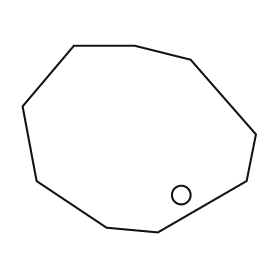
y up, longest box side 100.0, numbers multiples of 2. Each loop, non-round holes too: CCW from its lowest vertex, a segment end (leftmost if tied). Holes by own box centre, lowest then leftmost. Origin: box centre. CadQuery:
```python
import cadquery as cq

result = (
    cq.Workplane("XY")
    .moveTo(8.0, -40.0)
    .lineTo(46.0, -18.0)
    .lineTo(50.0, 2.0)
    .lineTo(22.0, 34.0)
    .lineTo(-2.0, 40.0)
    .lineTo(-28.0, 40.0)
    .lineTo(-50.0, 14.0)
    .lineTo(-44.0, -18.0)
    .lineTo(-14.0, -38.0)
    .close()
    .moveTo(18.0, -24.0)
    .circle(4.0)
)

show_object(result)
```